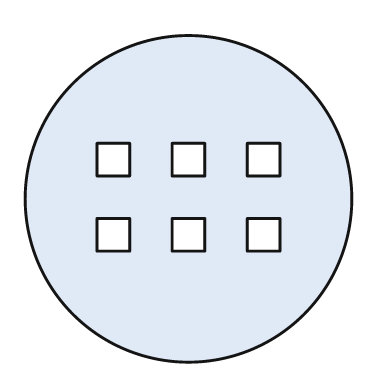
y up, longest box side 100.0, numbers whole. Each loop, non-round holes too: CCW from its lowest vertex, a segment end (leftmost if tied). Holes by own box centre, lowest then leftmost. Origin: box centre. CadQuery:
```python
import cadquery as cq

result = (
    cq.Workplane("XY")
    .moveTo(0.0, 0.0)
    .circle(50.0)
    .moveTo(-28.0, -16.0)
    .lineTo(-18.0, -16.0)
    .lineTo(-18.0, -6.0)
    .lineTo(-28.0, -6.0)
    .close()
    .moveTo(-5.0, -16.0)
    .lineTo(5.0, -16.0)
    .lineTo(5.0, -6.0)
    .lineTo(-5.0, -6.0)
    .close()
    .moveTo(18.0, -16.0)
    .lineTo(28.0, -16.0)
    .lineTo(28.0, -6.0)
    .lineTo(18.0, -6.0)
    .close()
    .moveTo(-28.0, 7.0)
    .lineTo(-18.0, 7.0)
    .lineTo(-18.0, 17.0)
    .lineTo(-28.0, 17.0)
    .close()
    .moveTo(-5.0, 7.0)
    .lineTo(5.0, 7.0)
    .lineTo(5.0, 17.0)
    .lineTo(-5.0, 17.0)
    .close()
    .moveTo(18.0, 7.0)
    .lineTo(28.0, 7.0)
    .lineTo(28.0, 17.0)
    .lineTo(18.0, 17.0)
    .close()
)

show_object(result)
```